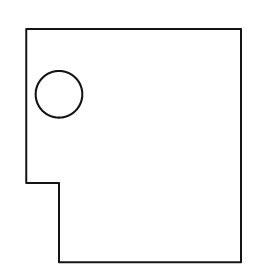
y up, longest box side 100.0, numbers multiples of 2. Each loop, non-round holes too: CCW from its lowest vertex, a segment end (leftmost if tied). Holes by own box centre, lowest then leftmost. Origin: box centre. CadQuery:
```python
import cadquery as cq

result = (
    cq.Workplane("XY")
    .moveTo(-32.0, -50.0)
    .lineTo(46.0, -50.0)
    .lineTo(46.0, 50.0)
    .lineTo(-46.0, 50.0)
    .lineTo(-46.0, -16.0)
    .lineTo(-32.0, -16.0)
    .close()
    .moveTo(-32.0, 22.0)
    .circle(10.0)
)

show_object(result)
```